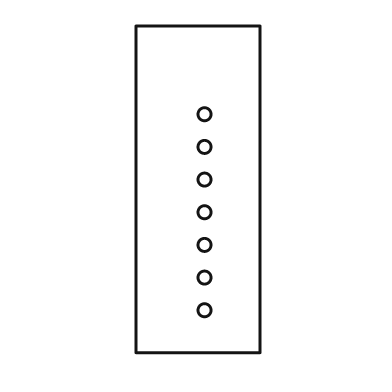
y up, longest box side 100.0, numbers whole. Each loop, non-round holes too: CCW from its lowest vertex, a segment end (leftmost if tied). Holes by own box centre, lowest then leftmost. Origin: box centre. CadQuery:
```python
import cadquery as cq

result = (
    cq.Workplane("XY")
    .moveTo(-19.0, -50.0)
    .lineTo(19.0, -50.0)
    .lineTo(19.0, 50.0)
    .lineTo(-19.0, 50.0)
    .close()
    .moveTo(2.0, -37.0)
    .circle(2.0)
    .moveTo(2.0, -27.0)
    .circle(2.0)
    .moveTo(2.0, -17.0)
    .circle(2.0)
    .moveTo(2.0, -7.0)
    .circle(2.0)
    .moveTo(2.0, 3.0)
    .circle(2.0)
    .moveTo(2.0, 13.0)
    .circle(2.0)
    .moveTo(2.0, 23.0)
    .circle(2.0)
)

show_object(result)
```